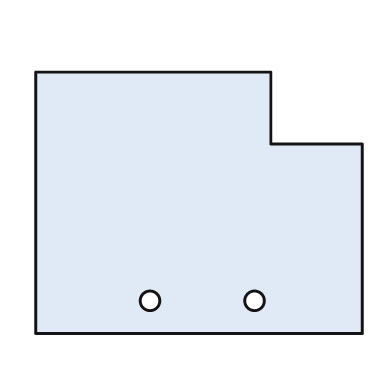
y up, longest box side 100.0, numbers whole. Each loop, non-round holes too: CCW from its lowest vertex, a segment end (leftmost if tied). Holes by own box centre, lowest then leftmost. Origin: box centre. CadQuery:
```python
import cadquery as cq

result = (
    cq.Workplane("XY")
    .moveTo(-50.0, -40.0)
    .lineTo(50.0, -40.0)
    .lineTo(50.0, 18.0)
    .lineTo(22.0, 18.0)
    .lineTo(22.0, 40.0)
    .lineTo(-50.0, 40.0)
    .close()
    .moveTo(-15.0, -30.0)
    .circle(3.0)
    .moveTo(17.0, -30.0)
    .circle(3.0)
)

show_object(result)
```